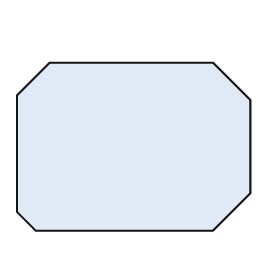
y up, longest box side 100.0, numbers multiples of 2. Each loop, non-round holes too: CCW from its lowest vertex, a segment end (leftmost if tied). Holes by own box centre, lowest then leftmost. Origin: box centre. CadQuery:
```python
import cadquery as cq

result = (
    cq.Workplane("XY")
    .moveTo(-42.0, -36.0)
    .lineTo(34.0, -36.0)
    .lineTo(50.0, -20.0)
    .lineTo(50.0, 20.0)
    .lineTo(34.0, 36.0)
    .lineTo(-36.0, 36.0)
    .lineTo(-50.0, 22.0)
    .lineTo(-50.0, -28.0)
    .close()
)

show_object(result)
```